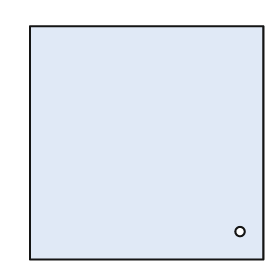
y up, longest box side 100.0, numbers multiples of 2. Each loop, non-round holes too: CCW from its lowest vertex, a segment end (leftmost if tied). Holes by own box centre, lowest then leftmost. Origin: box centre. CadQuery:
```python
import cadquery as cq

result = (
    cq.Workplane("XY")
    .moveTo(-50.0, -50.0)
    .lineTo(50.0, -50.0)
    .lineTo(50.0, 50.0)
    .lineTo(-50.0, 50.0)
    .close()
    .moveTo(40.0, -38.0)
    .circle(2.0)
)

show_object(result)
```